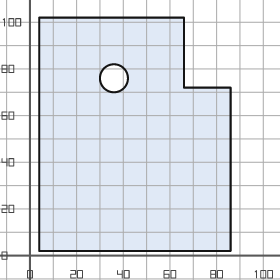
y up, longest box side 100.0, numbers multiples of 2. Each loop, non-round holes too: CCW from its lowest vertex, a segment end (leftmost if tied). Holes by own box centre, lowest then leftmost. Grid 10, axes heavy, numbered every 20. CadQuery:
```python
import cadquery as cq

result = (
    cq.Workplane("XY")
    .moveTo(4.0, 2.0)
    .lineTo(86.0, 2.0)
    .lineTo(86.0, 72.0)
    .lineTo(66.0, 72.0)
    .lineTo(66.0, 102.0)
    .lineTo(4.0, 102.0)
    .close()
    .moveTo(36.0, 76.0)
    .circle(6.0)
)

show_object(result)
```